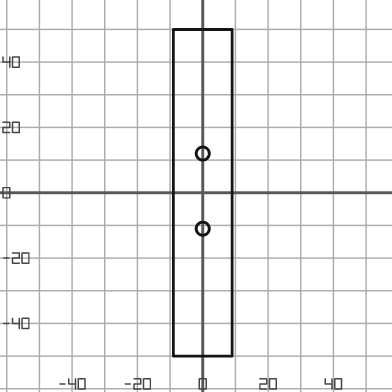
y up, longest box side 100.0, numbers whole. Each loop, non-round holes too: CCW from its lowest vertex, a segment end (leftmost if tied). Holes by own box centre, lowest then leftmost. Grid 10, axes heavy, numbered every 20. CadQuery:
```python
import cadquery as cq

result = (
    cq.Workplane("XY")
    .moveTo(-9.0, -50.0)
    .lineTo(9.0, -50.0)
    .lineTo(9.0, 50.0)
    .lineTo(-9.0, 50.0)
    .close()
    .moveTo(0.0, -11.0)
    .circle(2.0)
    .moveTo(0.0, 12.0)
    .circle(2.0)
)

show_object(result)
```